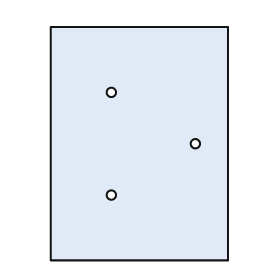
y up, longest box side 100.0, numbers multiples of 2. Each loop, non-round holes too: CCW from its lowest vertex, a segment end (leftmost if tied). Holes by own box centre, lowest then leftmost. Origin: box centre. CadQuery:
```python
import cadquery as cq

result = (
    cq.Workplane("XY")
    .moveTo(-38.0, -50.0)
    .lineTo(38.0, -50.0)
    .lineTo(38.0, 50.0)
    .lineTo(-38.0, 50.0)
    .close()
    .moveTo(-12.0, -22.0)
    .circle(2.0)
    .moveTo(24.0, 0.0)
    .circle(2.0)
    .moveTo(-12.0, 22.0)
    .circle(2.0)
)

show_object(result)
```